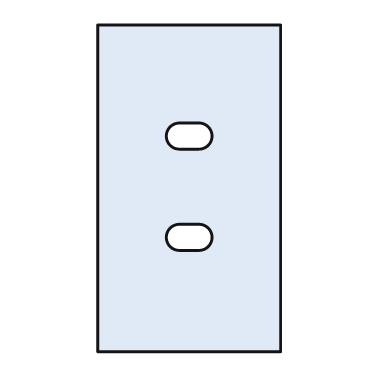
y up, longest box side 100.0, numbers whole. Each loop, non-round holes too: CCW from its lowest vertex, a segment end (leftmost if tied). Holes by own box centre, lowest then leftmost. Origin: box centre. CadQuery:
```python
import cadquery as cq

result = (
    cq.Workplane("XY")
    .moveTo(-28.0, -50.0)
    .lineTo(28.0, -50.0)
    .lineTo(28.0, 50.0)
    .lineTo(-28.0, 50.0)
    .close()
    .moveTo(-3.0, -19.0)
    .lineTo(3.0, -19.0)
    .threePointArc((7.0, -15.0), (3.0, -11.0))
    .lineTo(-3.0, -11.0)
    .threePointArc((-7.0, -15.0), (-3.0, -19.0))
    .close()
    .moveTo(-3.0, 12.0)
    .lineTo(3.0, 12.0)
    .threePointArc((7.0, 16.0), (3.0, 20.0))
    .lineTo(-3.0, 20.0)
    .threePointArc((-7.0, 16.0), (-3.0, 12.0))
    .close()
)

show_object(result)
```